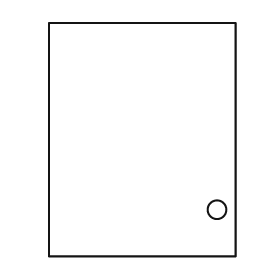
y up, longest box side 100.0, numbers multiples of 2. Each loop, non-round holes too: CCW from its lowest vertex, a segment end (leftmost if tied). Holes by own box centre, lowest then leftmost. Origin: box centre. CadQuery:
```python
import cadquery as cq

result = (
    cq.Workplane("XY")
    .moveTo(-40.0, -50.0)
    .lineTo(40.0, -50.0)
    .lineTo(40.0, 50.0)
    .lineTo(-40.0, 50.0)
    .close()
    .moveTo(32.0, -30.0)
    .circle(4.0)
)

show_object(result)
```